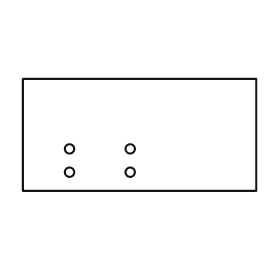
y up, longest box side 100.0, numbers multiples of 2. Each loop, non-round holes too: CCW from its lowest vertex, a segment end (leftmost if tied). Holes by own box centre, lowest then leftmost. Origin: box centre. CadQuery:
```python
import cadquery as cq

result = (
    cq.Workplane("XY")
    .moveTo(-50.0, -24.0)
    .lineTo(50.0, -24.0)
    .lineTo(50.0, 24.0)
    .lineTo(-50.0, 24.0)
    .close()
    .moveTo(-30.0, -16.0)
    .circle(2.0)
    .moveTo(-4.0, -16.0)
    .circle(2.0)
    .moveTo(-30.0, -6.0)
    .circle(2.0)
    .moveTo(-4.0, -6.0)
    .circle(2.0)
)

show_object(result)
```